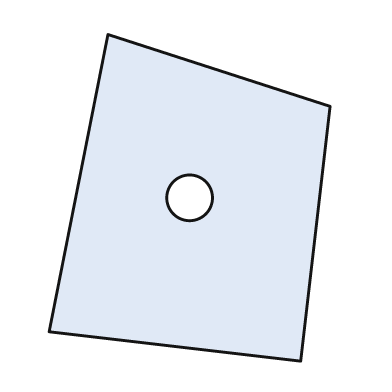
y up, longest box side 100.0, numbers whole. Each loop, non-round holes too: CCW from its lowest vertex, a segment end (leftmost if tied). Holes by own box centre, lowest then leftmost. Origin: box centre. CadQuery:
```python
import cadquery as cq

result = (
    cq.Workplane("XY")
    .moveTo(34.0, -50.0)
    .lineTo(43.0, 28.0)
    .lineTo(-25.0, 50.0)
    .lineTo(-43.0, -41.0)
    .close()
    .moveTo(0.0, 0.0)
    .circle(7.0)
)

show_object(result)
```